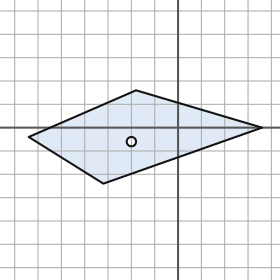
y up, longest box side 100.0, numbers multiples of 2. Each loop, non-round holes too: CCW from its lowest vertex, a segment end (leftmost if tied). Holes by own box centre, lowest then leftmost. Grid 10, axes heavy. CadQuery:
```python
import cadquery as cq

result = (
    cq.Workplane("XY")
    .moveTo(-32.0, -24.0)
    .lineTo(36.0, 0.0)
    .lineTo(-18.0, 16.0)
    .lineTo(-64.0, -4.0)
    .close()
    .moveTo(-20.0, -6.0)
    .circle(2.0)
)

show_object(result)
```